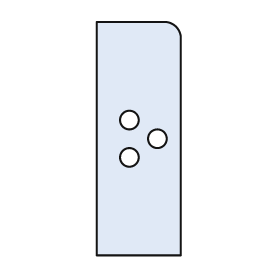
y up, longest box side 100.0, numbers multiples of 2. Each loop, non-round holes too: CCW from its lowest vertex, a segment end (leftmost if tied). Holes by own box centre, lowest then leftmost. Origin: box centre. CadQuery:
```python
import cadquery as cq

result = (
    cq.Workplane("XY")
    .moveTo(-18.0, -50.0)
    .lineTo(18.0, -50.0)
    .lineTo(18.0, 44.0)
    .threePointArc((16.0, 48.0), (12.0, 50.0))
    .lineTo(-18.0, 50.0)
    .close()
    .moveTo(-4.0, -8.0)
    .circle(4.0)
    .moveTo(8.0, 0.0)
    .circle(4.0)
    .moveTo(-4.0, 8.0)
    .circle(4.0)
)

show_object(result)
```